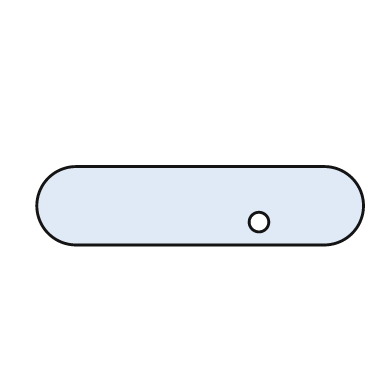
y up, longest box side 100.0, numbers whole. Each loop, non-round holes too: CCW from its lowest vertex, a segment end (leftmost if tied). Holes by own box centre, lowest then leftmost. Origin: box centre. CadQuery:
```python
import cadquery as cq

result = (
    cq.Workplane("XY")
    .moveTo(-38.0, -12.0)
    .lineTo(38.0, -12.0)
    .threePointArc((50.0, 0.0), (38.0, 12.0))
    .lineTo(-38.0, 12.0)
    .threePointArc((-50.0, 0.0), (-38.0, -12.0))
    .close()
    .moveTo(18.0, -5.0)
    .circle(3.0)
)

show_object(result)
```